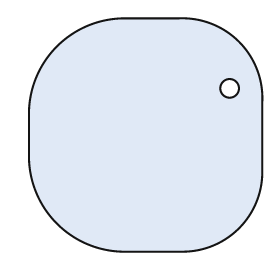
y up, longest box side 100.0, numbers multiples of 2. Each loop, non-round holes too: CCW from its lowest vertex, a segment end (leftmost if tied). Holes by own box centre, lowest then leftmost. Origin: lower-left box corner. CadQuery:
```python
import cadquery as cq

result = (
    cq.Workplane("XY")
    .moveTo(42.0, 0.0)
    .lineTo(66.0, 0.0)
    .threePointArc((90.0, 10.0), (100.0, 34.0))
    .lineTo(100.0, 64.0)
    .threePointArc((90.0, 90.0), (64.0, 100.0))
    .lineTo(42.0, 100.0)
    .threePointArc((12.0, 88.0), (0.0, 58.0))
    .lineTo(0.0, 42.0)
    .threePointArc((12.0, 12.0), (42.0, 0.0))
    .close()
    .moveTo(86.0, 70.0)
    .circle(4.0)
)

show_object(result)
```